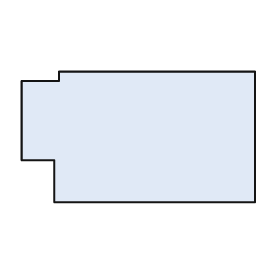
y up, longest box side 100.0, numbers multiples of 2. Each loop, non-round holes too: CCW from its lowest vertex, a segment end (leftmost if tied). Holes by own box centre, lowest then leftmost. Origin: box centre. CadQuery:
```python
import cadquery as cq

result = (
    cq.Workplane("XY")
    .moveTo(-36.0, -28.0)
    .lineTo(50.0, -28.0)
    .lineTo(50.0, 28.0)
    .lineTo(-34.0, 28.0)
    .lineTo(-34.0, 24.0)
    .lineTo(-50.0, 24.0)
    .lineTo(-50.0, -10.0)
    .lineTo(-36.0, -10.0)
    .close()
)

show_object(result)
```